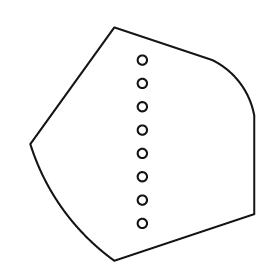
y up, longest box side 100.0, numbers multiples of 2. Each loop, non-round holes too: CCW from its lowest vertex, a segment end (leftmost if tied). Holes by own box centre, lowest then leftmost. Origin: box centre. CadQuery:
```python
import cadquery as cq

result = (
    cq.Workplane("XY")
    .moveTo(-12.0, -50.0)
    .lineTo(48.0, -30.0)
    .lineTo(48.0, 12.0)
    .threePointArc((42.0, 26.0), (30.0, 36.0))
    .lineTo(-12.0, 50.0)
    .lineTo(-48.0, 0.0)
    .threePointArc((-34.0, -28.0), (-12.0, -50.0))
    .close()
    .moveTo(0.0, -34.0)
    .circle(2.0)
    .moveTo(0.0, -24.0)
    .circle(2.0)
    .moveTo(0.0, -14.0)
    .circle(2.0)
    .moveTo(0.0, -4.0)
    .circle(2.0)
    .moveTo(0.0, 6.0)
    .circle(2.0)
    .moveTo(0.0, 16.0)
    .circle(2.0)
    .moveTo(0.0, 26.0)
    .circle(2.0)
    .moveTo(0.0, 36.0)
    .circle(2.0)
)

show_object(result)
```